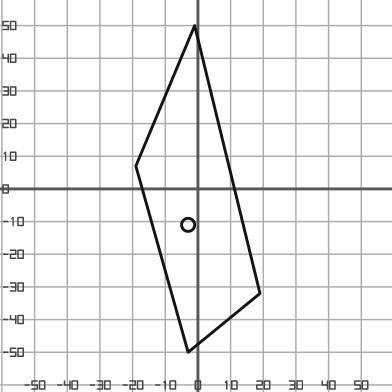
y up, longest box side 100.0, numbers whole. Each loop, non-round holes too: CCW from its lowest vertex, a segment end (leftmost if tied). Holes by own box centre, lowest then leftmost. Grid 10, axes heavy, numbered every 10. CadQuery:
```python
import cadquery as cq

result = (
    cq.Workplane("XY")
    .moveTo(-3.0, -50.0)
    .lineTo(19.0, -32.0)
    .lineTo(-1.0, 50.0)
    .lineTo(-19.0, 7.0)
    .close()
    .moveTo(-3.0, -11.0)
    .circle(2.0)
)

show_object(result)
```